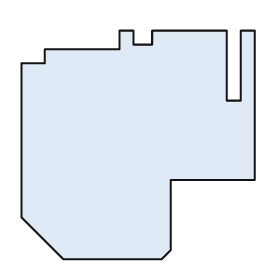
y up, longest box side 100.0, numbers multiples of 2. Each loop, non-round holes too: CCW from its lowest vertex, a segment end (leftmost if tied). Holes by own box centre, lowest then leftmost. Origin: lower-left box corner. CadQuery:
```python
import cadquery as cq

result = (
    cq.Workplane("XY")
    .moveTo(18.0, 0.0)
    .lineTo(60.0, 0.0)
    .lineTo(64.0, 4.0)
    .lineTo(64.0, 34.0)
    .lineTo(100.0, 34.0)
    .lineTo(100.0, 98.0)
    .lineTo(94.0, 98.0)
    .lineTo(94.0, 68.0)
    .lineTo(88.0, 68.0)
    .lineTo(88.0, 98.0)
    .lineTo(56.0, 98.0)
    .lineTo(56.0, 92.0)
    .lineTo(48.0, 92.0)
    .lineTo(48.0, 98.0)
    .lineTo(42.0, 98.0)
    .lineTo(42.0, 90.0)
    .lineTo(10.0, 90.0)
    .lineTo(10.0, 84.0)
    .lineTo(0.0, 84.0)
    .lineTo(0.0, 18.0)
    .close()
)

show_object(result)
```